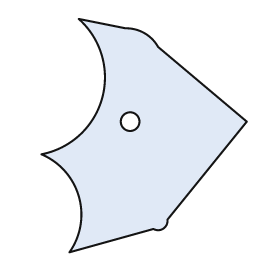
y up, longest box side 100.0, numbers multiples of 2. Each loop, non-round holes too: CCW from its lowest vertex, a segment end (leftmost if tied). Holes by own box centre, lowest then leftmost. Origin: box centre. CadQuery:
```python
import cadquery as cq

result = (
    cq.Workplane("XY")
    .moveTo(-32.0, -50.0)
    .lineTo(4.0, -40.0)
    .threePointArc((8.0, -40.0), (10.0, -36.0))
    .lineTo(44.0, 6.0)
    .lineTo(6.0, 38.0)
    .threePointArc((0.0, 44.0), (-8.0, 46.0))
    .lineTo(-28.0, 50.0)
    .threePointArc((-18.0, 16.0), (-44.0, -8.0))
    .threePointArc((-28.0, -26.0), (-32.0, -50.0))
    .close()
    .moveTo(-6.0, 6.0)
    .circle(4.0)
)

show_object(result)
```